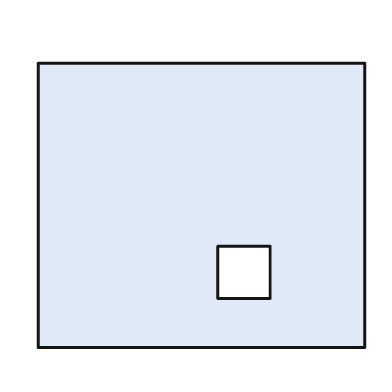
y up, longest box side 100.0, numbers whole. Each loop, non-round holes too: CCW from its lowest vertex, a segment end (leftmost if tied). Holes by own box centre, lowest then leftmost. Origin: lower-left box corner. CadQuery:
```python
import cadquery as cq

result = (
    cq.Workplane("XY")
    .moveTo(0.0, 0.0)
    .lineTo(100.0, 0.0)
    .lineTo(100.0, 87.0)
    .lineTo(0.0, 87.0)
    .close()
    .moveTo(55.0, 15.0)
    .lineTo(71.0, 15.0)
    .lineTo(71.0, 31.0)
    .lineTo(55.0, 31.0)
    .close()
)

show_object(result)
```